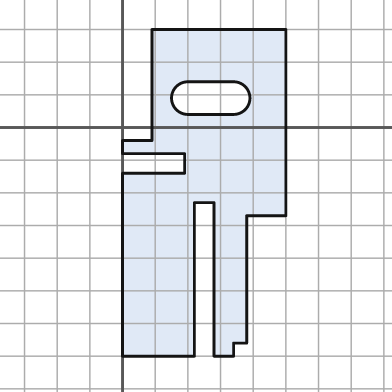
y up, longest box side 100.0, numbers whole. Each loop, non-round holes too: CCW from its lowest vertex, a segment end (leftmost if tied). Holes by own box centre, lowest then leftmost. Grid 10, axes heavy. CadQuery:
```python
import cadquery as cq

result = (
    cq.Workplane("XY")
    .moveTo(0.0, -70.0)
    .lineTo(22.0, -70.0)
    .lineTo(22.0, -23.0)
    .lineTo(28.0, -23.0)
    .lineTo(28.0, -70.0)
    .lineTo(34.0, -70.0)
    .lineTo(34.0, -66.0)
    .lineTo(38.0, -66.0)
    .lineTo(38.0, -27.0)
    .lineTo(50.0, -27.0)
    .lineTo(50.0, 30.0)
    .lineTo(9.0, 30.0)
    .lineTo(9.0, -4.0)
    .lineTo(0.0, -4.0)
    .lineTo(0.0, -8.0)
    .lineTo(19.0, -8.0)
    .lineTo(19.0, -14.0)
    .lineTo(0.0, -14.0)
    .close()
    .moveTo(20.0, 4.0)
    .lineTo(34.0, 4.0)
    .threePointArc((39.0, 9.0), (34.0, 14.0))
    .lineTo(20.0, 14.0)
    .threePointArc((15.0, 9.0), (20.0, 4.0))
    .close()
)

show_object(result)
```